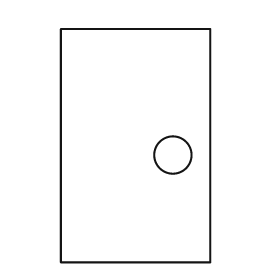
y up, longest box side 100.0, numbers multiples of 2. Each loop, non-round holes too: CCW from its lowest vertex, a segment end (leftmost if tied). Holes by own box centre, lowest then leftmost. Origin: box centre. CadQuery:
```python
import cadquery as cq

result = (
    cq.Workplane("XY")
    .moveTo(-32.0, -50.0)
    .lineTo(32.0, -50.0)
    .lineTo(32.0, 50.0)
    .lineTo(-32.0, 50.0)
    .close()
    .moveTo(16.0, -4.0)
    .circle(8.0)
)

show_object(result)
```